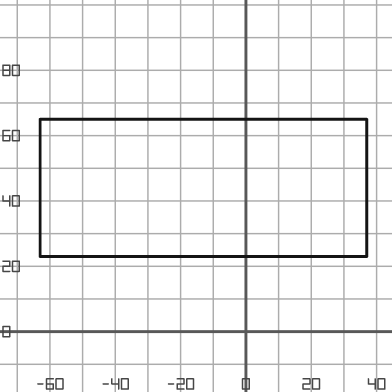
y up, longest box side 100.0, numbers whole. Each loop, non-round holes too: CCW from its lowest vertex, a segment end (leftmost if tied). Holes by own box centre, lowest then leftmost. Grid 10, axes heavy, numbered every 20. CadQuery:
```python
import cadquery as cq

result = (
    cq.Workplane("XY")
    .moveTo(-63.0, 23.0)
    .lineTo(37.0, 23.0)
    .lineTo(37.0, 65.0)
    .lineTo(-63.0, 65.0)
    .close()
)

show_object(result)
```